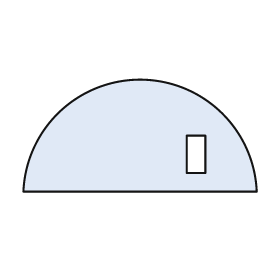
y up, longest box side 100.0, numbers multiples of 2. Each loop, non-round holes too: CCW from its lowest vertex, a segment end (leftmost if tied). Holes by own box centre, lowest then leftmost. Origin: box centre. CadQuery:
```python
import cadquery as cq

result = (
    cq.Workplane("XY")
    .moveTo(-50.0, -24.0)
    .lineTo(50.0, -24.0)
    .threePointArc((0.0, 24.0), (-50.0, -24.0))
    .close()
    .moveTo(20.0, -16.0)
    .lineTo(28.0, -16.0)
    .lineTo(28.0, 0.0)
    .lineTo(20.0, 0.0)
    .close()
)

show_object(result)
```